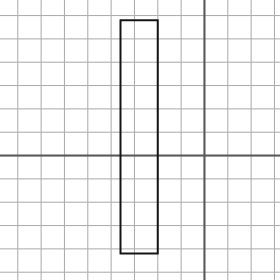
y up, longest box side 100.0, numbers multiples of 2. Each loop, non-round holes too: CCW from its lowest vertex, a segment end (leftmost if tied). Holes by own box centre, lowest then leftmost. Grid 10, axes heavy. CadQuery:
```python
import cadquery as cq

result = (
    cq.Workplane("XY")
    .moveTo(-36.0, -42.0)
    .lineTo(-20.0, -42.0)
    .lineTo(-20.0, 58.0)
    .lineTo(-36.0, 58.0)
    .close()
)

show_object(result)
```